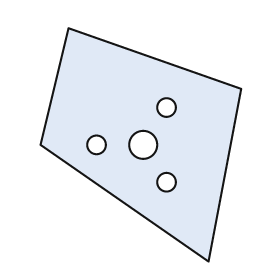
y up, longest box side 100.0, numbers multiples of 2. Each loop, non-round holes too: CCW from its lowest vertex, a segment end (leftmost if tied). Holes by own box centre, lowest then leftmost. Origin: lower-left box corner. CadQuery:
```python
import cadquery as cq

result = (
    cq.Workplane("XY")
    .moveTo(72.0, 0.0)
    .lineTo(86.0, 74.0)
    .lineTo(12.0, 100.0)
    .lineTo(0.0, 50.0)
    .close()
    .moveTo(54.0, 34.0)
    .circle(4.0)
    .moveTo(24.0, 50.0)
    .circle(4.0)
    .moveTo(44.0, 50.0)
    .circle(6.0)
    .moveTo(54.0, 66.0)
    .circle(4.0)
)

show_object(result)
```